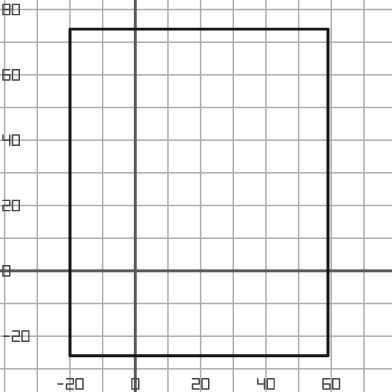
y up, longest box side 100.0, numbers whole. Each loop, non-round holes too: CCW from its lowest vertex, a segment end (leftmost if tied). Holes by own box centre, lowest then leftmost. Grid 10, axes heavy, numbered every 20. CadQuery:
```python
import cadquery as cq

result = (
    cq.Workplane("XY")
    .moveTo(-20.0, -26.0)
    .lineTo(59.0, -26.0)
    .lineTo(59.0, 74.0)
    .lineTo(-20.0, 74.0)
    .close()
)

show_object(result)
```